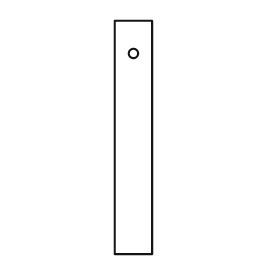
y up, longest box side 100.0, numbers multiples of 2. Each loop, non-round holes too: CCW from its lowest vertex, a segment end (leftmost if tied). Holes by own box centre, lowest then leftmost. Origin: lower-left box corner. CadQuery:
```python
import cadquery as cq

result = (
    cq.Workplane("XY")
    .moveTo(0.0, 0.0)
    .lineTo(16.0, 0.0)
    .lineTo(16.0, 100.0)
    .lineTo(0.0, 100.0)
    .close()
    .moveTo(8.0, 86.0)
    .circle(2.0)
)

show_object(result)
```